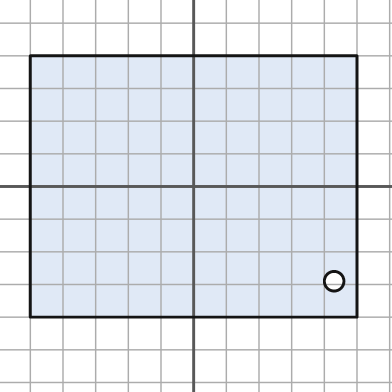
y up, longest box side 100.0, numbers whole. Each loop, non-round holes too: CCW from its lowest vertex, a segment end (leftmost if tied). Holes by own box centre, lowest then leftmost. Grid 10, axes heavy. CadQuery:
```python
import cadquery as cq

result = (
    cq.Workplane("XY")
    .moveTo(-50.0, -40.0)
    .lineTo(50.0, -40.0)
    .lineTo(50.0, 40.0)
    .lineTo(-50.0, 40.0)
    .close()
    .moveTo(43.0, -29.0)
    .circle(3.0)
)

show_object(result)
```